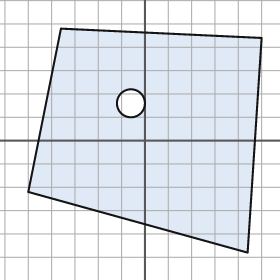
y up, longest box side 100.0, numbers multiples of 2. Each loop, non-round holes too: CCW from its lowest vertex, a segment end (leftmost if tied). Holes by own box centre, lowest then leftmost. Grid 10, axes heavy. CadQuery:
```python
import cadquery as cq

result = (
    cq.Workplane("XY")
    .moveTo(44.0, -48.0)
    .lineTo(50.0, 44.0)
    .lineTo(-36.0, 48.0)
    .lineTo(-50.0, -22.0)
    .close()
    .moveTo(-6.0, 16.0)
    .circle(6.0)
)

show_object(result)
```